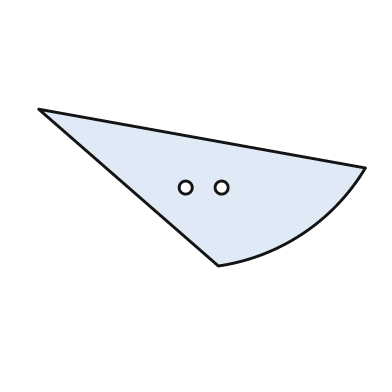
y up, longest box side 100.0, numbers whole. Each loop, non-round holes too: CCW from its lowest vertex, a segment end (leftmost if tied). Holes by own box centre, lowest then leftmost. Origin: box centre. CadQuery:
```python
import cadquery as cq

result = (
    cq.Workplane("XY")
    .moveTo(5.0, -24.0)
    .threePointArc((31.0, -14.0), (50.0, 6.0))
    .lineTo(-50.0, 24.0)
    .close()
    .moveTo(-5.0, 0.0)
    .circle(2.0)
    .moveTo(6.0, 0.0)
    .circle(2.0)
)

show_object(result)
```